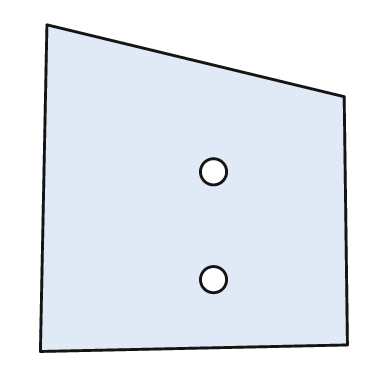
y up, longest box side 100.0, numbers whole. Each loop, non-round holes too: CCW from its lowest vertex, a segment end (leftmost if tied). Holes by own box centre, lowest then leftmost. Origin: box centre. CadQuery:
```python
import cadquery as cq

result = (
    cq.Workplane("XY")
    .moveTo(-47.0, -50.0)
    .lineTo(47.0, -48.0)
    .lineTo(46.0, 28.0)
    .lineTo(-45.0, 50.0)
    .close()
    .moveTo(6.0, -28.0)
    .circle(4.0)
    .moveTo(6.0, 5.0)
    .circle(4.0)
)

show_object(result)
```